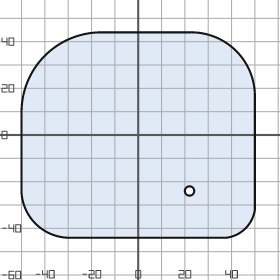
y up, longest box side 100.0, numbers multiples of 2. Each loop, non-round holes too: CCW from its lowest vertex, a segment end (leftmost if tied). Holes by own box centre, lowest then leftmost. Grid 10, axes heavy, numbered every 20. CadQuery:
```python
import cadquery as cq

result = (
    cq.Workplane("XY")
    .moveTo(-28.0, -44.0)
    .lineTo(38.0, -44.0)
    .threePointArc((46.0, -40.0), (50.0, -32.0))
    .lineTo(50.0, 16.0)
    .threePointArc((42.0, 36.0), (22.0, 44.0))
    .lineTo(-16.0, 44.0)
    .threePointArc((-40.0, 34.0), (-50.0, 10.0))
    .lineTo(-50.0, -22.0)
    .threePointArc((-44.0, -38.0), (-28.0, -44.0))
    .close()
    .moveTo(22.0, -24.0)
    .circle(2.0)
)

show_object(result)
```